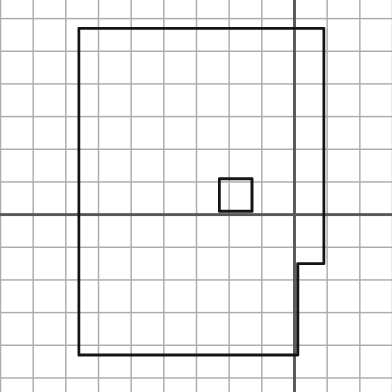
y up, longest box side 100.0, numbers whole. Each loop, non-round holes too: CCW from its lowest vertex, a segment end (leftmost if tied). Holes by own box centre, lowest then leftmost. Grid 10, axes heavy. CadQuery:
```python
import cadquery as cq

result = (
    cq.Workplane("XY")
    .moveTo(-66.0, -43.0)
    .lineTo(1.0, -43.0)
    .lineTo(1.0, -15.0)
    .lineTo(9.0, -15.0)
    .lineTo(9.0, 57.0)
    .lineTo(-66.0, 57.0)
    .close()
    .moveTo(-23.0, 1.0)
    .lineTo(-13.0, 1.0)
    .lineTo(-13.0, 11.0)
    .lineTo(-23.0, 11.0)
    .close()
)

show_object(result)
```